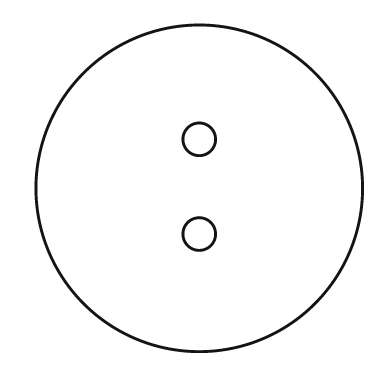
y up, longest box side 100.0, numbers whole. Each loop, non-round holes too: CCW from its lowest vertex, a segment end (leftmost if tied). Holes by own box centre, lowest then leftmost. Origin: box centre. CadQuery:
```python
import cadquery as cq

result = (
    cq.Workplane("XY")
    .moveTo(0.0, 0.0)
    .circle(50.0)
    .moveTo(0.0, -14.0)
    .circle(5.0)
    .moveTo(0.0, 15.0)
    .circle(5.0)
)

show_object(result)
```